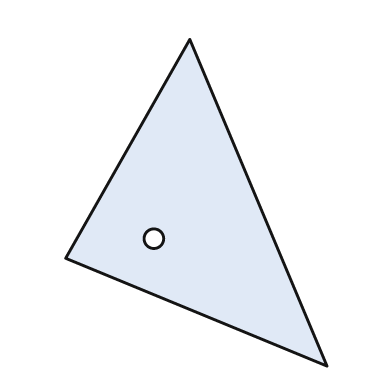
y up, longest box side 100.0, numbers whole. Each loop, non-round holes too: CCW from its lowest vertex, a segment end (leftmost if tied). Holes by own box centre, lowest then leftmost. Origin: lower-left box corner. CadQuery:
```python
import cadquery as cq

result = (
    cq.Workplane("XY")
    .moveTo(80.0, 0.0)
    .lineTo(38.0, 100.0)
    .lineTo(0.0, 33.0)
    .close()
    .moveTo(27.0, 39.0)
    .circle(3.0)
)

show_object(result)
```